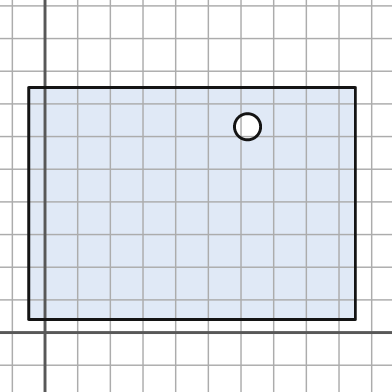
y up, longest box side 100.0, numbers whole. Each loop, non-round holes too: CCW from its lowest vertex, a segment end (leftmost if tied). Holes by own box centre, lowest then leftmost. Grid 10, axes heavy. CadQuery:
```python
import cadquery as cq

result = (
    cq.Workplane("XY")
    .moveTo(-5.0, 4.0)
    .lineTo(95.0, 4.0)
    .lineTo(95.0, 75.0)
    .lineTo(-5.0, 75.0)
    .close()
    .moveTo(62.0, 63.0)
    .circle(4.0)
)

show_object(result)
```